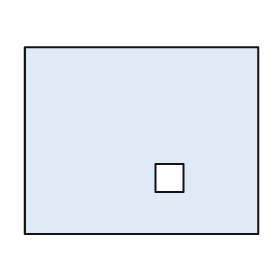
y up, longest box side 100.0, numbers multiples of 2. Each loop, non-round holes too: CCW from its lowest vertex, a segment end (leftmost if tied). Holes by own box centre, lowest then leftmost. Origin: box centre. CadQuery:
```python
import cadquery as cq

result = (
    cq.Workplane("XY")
    .moveTo(-50.0, -40.0)
    .lineTo(50.0, -40.0)
    .lineTo(50.0, 40.0)
    .lineTo(-50.0, 40.0)
    .close()
    .moveTo(6.0, -22.0)
    .lineTo(18.0, -22.0)
    .lineTo(18.0, -10.0)
    .lineTo(6.0, -10.0)
    .close()
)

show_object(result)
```